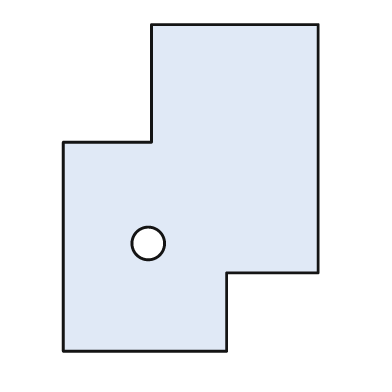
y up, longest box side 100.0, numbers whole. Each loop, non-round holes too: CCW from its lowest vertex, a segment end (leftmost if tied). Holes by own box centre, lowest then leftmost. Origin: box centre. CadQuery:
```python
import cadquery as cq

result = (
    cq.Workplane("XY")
    .moveTo(-39.0, -50.0)
    .lineTo(11.0, -50.0)
    .lineTo(11.0, -26.0)
    .lineTo(39.0, -26.0)
    .lineTo(39.0, 50.0)
    .lineTo(-12.0, 50.0)
    .lineTo(-12.0, 14.0)
    .lineTo(-39.0, 14.0)
    .close()
    .moveTo(-13.0, -17.0)
    .circle(5.0)
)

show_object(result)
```